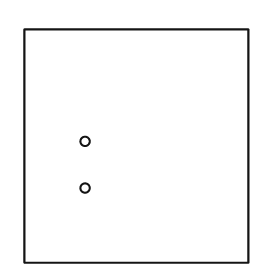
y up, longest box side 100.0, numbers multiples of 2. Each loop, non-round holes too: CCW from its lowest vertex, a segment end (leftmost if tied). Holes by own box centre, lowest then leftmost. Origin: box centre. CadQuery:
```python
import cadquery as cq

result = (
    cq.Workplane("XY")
    .moveTo(-48.0, -50.0)
    .lineTo(48.0, -50.0)
    .lineTo(48.0, 50.0)
    .lineTo(-48.0, 50.0)
    .close()
    .moveTo(-22.0, -18.0)
    .circle(2.0)
    .moveTo(-22.0, 2.0)
    .circle(2.0)
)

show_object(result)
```